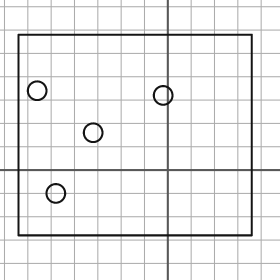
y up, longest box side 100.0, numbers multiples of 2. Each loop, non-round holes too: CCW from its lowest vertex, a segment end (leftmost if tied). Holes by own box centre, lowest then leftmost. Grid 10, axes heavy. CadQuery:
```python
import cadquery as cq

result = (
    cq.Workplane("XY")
    .moveTo(-64.0, -28.0)
    .lineTo(36.0, -28.0)
    .lineTo(36.0, 58.0)
    .lineTo(-64.0, 58.0)
    .close()
    .moveTo(-48.0, -10.0)
    .circle(4.0)
    .moveTo(-32.0, 16.0)
    .circle(4.0)
    .moveTo(-2.0, 32.0)
    .circle(4.0)
    .moveTo(-56.0, 34.0)
    .circle(4.0)
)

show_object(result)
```